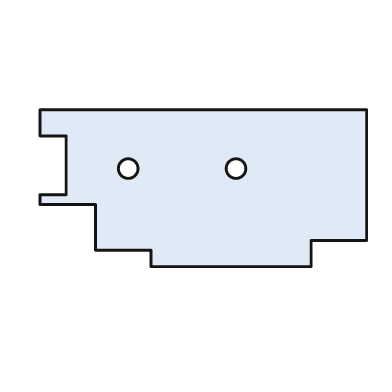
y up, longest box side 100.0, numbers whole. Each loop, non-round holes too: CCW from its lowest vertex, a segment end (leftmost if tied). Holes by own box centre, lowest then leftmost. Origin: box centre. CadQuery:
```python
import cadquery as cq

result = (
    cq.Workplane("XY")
    .moveTo(-16.0, -24.0)
    .lineTo(33.0, -24.0)
    .lineTo(33.0, -16.0)
    .lineTo(50.0, -16.0)
    .lineTo(50.0, 24.0)
    .lineTo(-50.0, 24.0)
    .lineTo(-50.0, 16.0)
    .lineTo(-42.0, 16.0)
    .lineTo(-42.0, -2.0)
    .lineTo(-50.0, -2.0)
    .lineTo(-50.0, -5.0)
    .lineTo(-33.0, -5.0)
    .lineTo(-33.0, -19.0)
    .lineTo(-16.0, -19.0)
    .close()
    .moveTo(-23.0, 6.0)
    .circle(3.0)
    .moveTo(10.0, 6.0)
    .circle(3.0)
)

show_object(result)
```